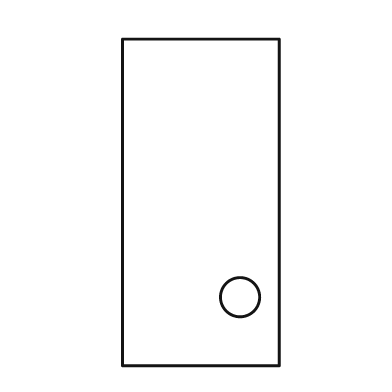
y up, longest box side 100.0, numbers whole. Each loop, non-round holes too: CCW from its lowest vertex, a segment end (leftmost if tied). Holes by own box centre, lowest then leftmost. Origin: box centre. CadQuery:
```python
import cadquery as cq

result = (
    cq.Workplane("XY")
    .moveTo(-24.0, -50.0)
    .lineTo(24.0, -50.0)
    .lineTo(24.0, 50.0)
    .lineTo(-24.0, 50.0)
    .close()
    .moveTo(12.0, -29.0)
    .circle(6.0)
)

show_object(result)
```